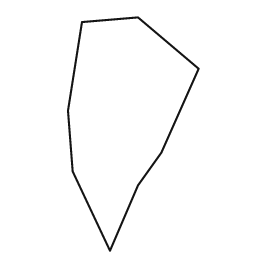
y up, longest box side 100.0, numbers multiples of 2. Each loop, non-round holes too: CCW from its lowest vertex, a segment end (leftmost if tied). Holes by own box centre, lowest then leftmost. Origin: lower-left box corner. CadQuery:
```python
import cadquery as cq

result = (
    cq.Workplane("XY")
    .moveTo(18.0, 0.0)
    .lineTo(30.0, 28.0)
    .lineTo(40.0, 42.0)
    .lineTo(56.0, 78.0)
    .lineTo(30.0, 100.0)
    .lineTo(6.0, 98.0)
    .lineTo(0.0, 60.0)
    .lineTo(2.0, 34.0)
    .close()
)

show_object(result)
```